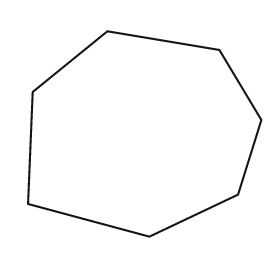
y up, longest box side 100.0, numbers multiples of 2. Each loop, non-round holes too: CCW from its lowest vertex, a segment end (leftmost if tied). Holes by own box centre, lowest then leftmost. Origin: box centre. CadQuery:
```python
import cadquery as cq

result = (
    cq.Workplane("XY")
    .moveTo(2.0, -44.0)
    .lineTo(40.0, -26.0)
    .lineTo(50.0, 6.0)
    .lineTo(32.0, 36.0)
    .lineTo(-16.0, 44.0)
    .lineTo(-48.0, 18.0)
    .lineTo(-50.0, -30.0)
    .close()
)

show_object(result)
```